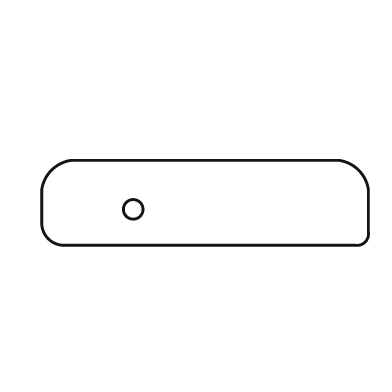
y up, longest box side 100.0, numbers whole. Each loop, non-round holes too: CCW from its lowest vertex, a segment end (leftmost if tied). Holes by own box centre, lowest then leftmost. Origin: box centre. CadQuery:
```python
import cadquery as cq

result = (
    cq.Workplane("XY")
    .moveTo(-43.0, -13.0)
    .lineTo(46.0, -13.0)
    .threePointArc((49.0, -12.0), (50.0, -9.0))
    .lineTo(50.0, 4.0)
    .threePointArc((47.0, 10.0), (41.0, 13.0))
    .lineTo(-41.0, 13.0)
    .threePointArc((-47.0, 10.0), (-50.0, 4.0))
    .lineTo(-50.0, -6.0)
    .threePointArc((-48.0, -11.0), (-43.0, -13.0))
    .close()
    .moveTo(-22.0, -2.0)
    .circle(3.0)
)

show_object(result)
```